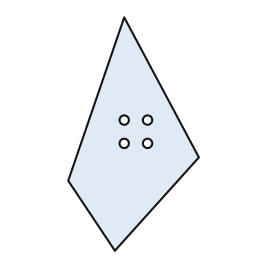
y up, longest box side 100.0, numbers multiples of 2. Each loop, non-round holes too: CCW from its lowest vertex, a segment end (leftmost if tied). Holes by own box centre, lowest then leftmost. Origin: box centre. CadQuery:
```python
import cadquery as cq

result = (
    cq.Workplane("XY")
    .moveTo(-8.0, -50.0)
    .lineTo(28.0, -10.0)
    .lineTo(-4.0, 50.0)
    .lineTo(-28.0, -20.0)
    .close()
    .moveTo(-4.0, -4.0)
    .circle(2.0)
    .moveTo(6.0, -4.0)
    .circle(2.0)
    .moveTo(-4.0, 6.0)
    .circle(2.0)
    .moveTo(6.0, 6.0)
    .circle(2.0)
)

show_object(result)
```